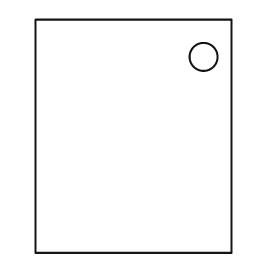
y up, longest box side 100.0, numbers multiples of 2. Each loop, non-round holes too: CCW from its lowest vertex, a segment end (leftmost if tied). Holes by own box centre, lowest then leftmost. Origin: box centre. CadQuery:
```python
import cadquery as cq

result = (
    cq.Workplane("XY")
    .moveTo(-42.0, -50.0)
    .lineTo(42.0, -50.0)
    .lineTo(42.0, 50.0)
    .lineTo(-42.0, 50.0)
    .close()
    .moveTo(30.0, 34.0)
    .circle(6.0)
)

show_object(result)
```